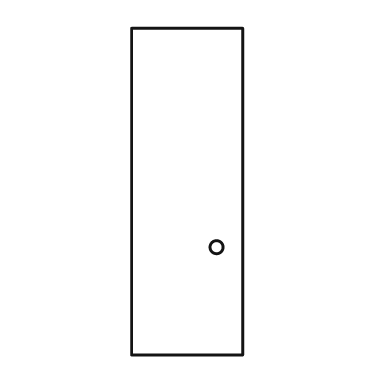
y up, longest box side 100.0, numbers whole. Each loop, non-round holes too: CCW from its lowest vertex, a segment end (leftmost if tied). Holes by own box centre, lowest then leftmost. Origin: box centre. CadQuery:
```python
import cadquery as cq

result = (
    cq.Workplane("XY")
    .moveTo(-17.0, -50.0)
    .lineTo(17.0, -50.0)
    .lineTo(17.0, 50.0)
    .lineTo(-17.0, 50.0)
    .close()
    .moveTo(9.0, -17.0)
    .circle(2.0)
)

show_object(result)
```